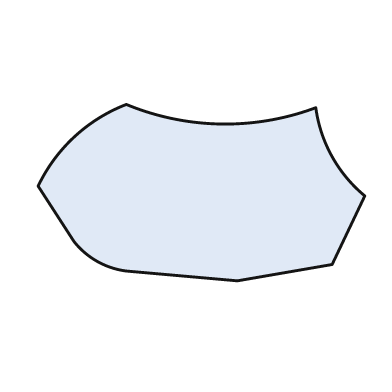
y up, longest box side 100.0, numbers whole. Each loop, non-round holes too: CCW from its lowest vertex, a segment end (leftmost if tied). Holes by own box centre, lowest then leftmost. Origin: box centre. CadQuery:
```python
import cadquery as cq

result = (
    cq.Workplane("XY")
    .moveTo(11.0, -27.0)
    .lineTo(40.0, -22.0)
    .lineTo(50.0, -1.0)
    .threePointArc((40.0, 11.0), (35.0, 26.0))
    .threePointArc((6.0, 21.0), (-23.0, 27.0))
    .threePointArc((-39.0, 17.0), (-50.0, 2.0))
    .lineTo(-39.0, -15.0)
    .threePointArc((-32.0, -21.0), (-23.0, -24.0))
    .close()
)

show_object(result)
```